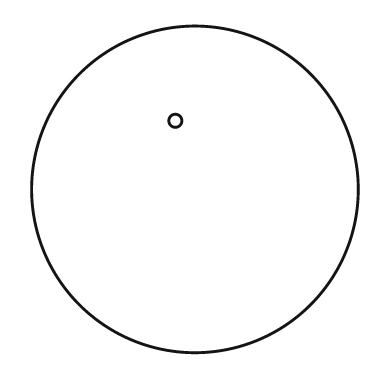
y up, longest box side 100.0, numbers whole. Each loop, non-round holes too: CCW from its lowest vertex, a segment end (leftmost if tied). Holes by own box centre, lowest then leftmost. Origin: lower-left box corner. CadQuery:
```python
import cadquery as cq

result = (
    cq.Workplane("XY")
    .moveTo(50.0, 50.0)
    .circle(50.0)
    .moveTo(44.0, 71.0)
    .circle(2.0)
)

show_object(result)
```